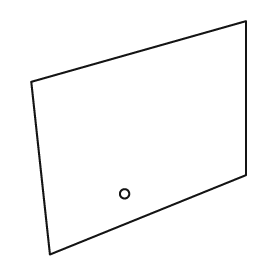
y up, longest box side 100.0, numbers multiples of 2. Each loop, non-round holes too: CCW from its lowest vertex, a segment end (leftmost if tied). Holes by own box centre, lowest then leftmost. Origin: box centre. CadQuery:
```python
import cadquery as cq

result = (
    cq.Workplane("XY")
    .moveTo(-38.0, -50.0)
    .lineTo(46.0, -16.0)
    .lineTo(46.0, 50.0)
    .lineTo(-46.0, 24.0)
    .close()
    .moveTo(-6.0, -24.0)
    .circle(2.0)
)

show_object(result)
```